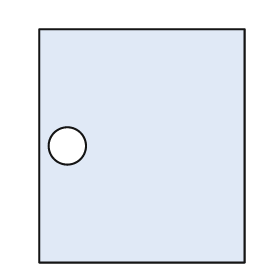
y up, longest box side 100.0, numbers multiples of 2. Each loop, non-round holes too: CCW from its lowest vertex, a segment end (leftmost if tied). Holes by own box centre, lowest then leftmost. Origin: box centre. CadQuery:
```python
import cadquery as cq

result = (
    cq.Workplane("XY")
    .moveTo(-44.0, -50.0)
    .lineTo(44.0, -50.0)
    .lineTo(44.0, 50.0)
    .lineTo(-44.0, 50.0)
    .close()
    .moveTo(-32.0, 0.0)
    .circle(8.0)
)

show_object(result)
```